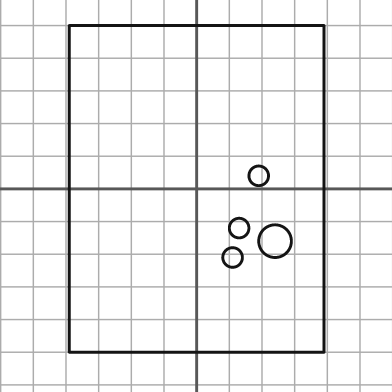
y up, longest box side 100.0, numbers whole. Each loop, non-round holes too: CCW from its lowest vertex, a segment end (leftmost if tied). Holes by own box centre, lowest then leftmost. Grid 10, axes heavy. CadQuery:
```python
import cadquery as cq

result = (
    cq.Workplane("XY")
    .moveTo(-39.0, -50.0)
    .lineTo(39.0, -50.0)
    .lineTo(39.0, 50.0)
    .lineTo(-39.0, 50.0)
    .close()
    .moveTo(11.0, -21.0)
    .circle(3.0)
    .moveTo(24.0, -16.0)
    .circle(5.0)
    .moveTo(13.0, -12.0)
    .circle(3.0)
    .moveTo(19.0, 4.0)
    .circle(3.0)
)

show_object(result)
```